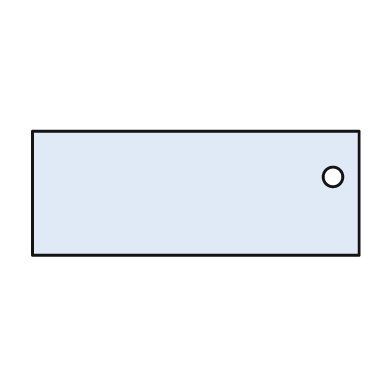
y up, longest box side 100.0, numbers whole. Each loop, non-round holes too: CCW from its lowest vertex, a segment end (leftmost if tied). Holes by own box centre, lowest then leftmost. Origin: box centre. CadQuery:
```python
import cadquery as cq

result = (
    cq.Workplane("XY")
    .moveTo(-50.0, -19.0)
    .lineTo(50.0, -19.0)
    .lineTo(50.0, 19.0)
    .lineTo(-50.0, 19.0)
    .close()
    .moveTo(42.0, 5.0)
    .circle(3.0)
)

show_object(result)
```